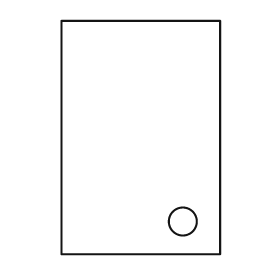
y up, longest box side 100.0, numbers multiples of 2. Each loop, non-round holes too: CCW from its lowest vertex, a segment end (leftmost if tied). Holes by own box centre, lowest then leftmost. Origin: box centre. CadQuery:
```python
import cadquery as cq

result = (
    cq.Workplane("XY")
    .moveTo(-34.0, -50.0)
    .lineTo(34.0, -50.0)
    .lineTo(34.0, 50.0)
    .lineTo(-34.0, 50.0)
    .close()
    .moveTo(18.0, -36.0)
    .circle(6.0)
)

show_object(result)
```